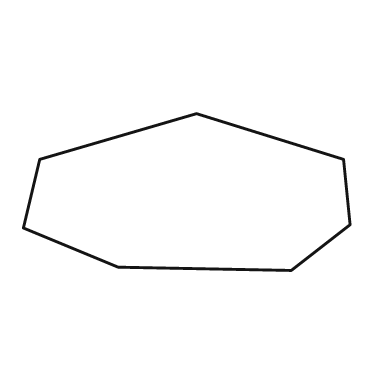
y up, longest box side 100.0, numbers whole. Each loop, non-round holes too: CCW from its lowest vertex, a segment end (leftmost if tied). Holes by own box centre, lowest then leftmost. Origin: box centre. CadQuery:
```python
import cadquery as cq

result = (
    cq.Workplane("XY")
    .moveTo(32.0, -24.0)
    .lineTo(50.0, -10.0)
    .lineTo(48.0, 10.0)
    .lineTo(3.0, 24.0)
    .lineTo(-45.0, 10.0)
    .lineTo(-50.0, -11.0)
    .lineTo(-21.0, -23.0)
    .close()
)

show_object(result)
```